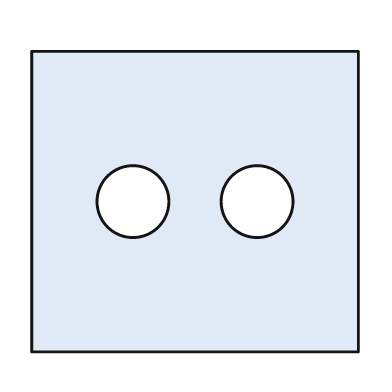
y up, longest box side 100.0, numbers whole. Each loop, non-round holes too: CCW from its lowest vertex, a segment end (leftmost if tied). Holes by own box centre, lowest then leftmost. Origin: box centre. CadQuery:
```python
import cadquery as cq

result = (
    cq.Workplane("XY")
    .moveTo(-50.0, -46.0)
    .lineTo(50.0, -46.0)
    .lineTo(50.0, 46.0)
    .lineTo(-50.0, 46.0)
    .close()
    .moveTo(-19.0, 0.0)
    .circle(11.0)
    .moveTo(19.0, 0.0)
    .circle(11.0)
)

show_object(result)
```